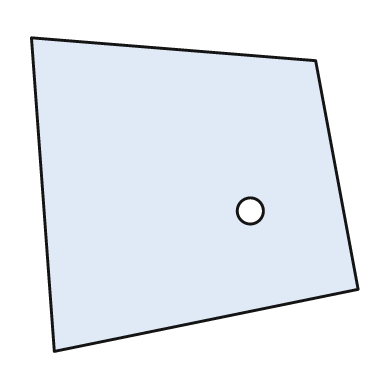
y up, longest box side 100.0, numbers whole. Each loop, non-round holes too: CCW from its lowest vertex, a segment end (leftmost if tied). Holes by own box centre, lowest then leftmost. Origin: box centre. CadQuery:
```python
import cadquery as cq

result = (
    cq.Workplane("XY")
    .moveTo(-43.0, -48.0)
    .lineTo(50.0, -29.0)
    .lineTo(37.0, 41.0)
    .lineTo(-50.0, 48.0)
    .close()
    .moveTo(17.0, -5.0)
    .circle(4.0)
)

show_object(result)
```